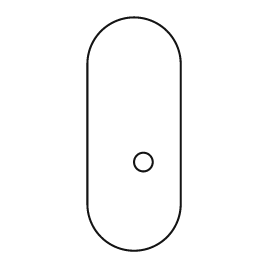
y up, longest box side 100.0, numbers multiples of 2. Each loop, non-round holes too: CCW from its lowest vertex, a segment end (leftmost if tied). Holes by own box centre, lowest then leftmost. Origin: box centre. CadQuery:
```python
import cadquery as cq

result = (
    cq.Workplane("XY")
    .moveTo(-20.0, -30.0)
    .threePointArc((0.0, -50.0), (20.0, -30.0))
    .lineTo(20.0, 30.0)
    .threePointArc((0.0, 50.0), (-20.0, 30.0))
    .close()
    .moveTo(4.0, -12.0)
    .circle(4.0)
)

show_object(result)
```